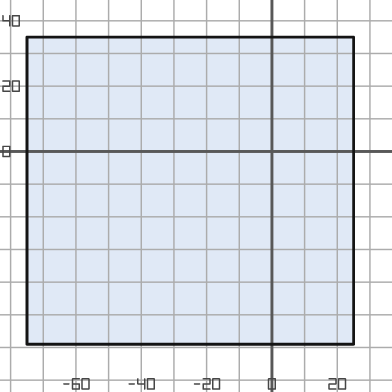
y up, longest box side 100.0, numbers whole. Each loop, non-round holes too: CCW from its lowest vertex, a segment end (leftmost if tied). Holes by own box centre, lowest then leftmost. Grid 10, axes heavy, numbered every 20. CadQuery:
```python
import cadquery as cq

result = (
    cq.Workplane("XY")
    .moveTo(-75.0, -59.0)
    .lineTo(25.0, -59.0)
    .lineTo(25.0, 35.0)
    .lineTo(-75.0, 35.0)
    .close()
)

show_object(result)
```